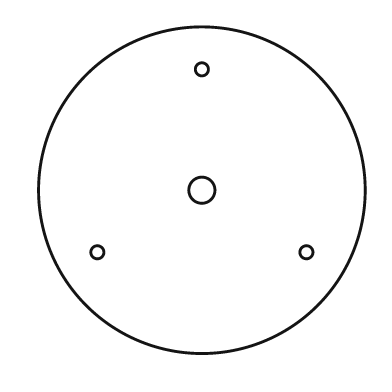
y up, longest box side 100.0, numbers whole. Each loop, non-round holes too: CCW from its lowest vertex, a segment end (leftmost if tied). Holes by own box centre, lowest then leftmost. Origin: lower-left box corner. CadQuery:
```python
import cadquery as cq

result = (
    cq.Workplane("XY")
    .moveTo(50.0, 50.0)
    .circle(50.0)
    .moveTo(18.0, 31.0)
    .circle(2.0)
    .moveTo(82.0, 31.0)
    .circle(2.0)
    .moveTo(50.0, 50.0)
    .circle(4.0)
    .moveTo(50.0, 87.0)
    .circle(2.0)
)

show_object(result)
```